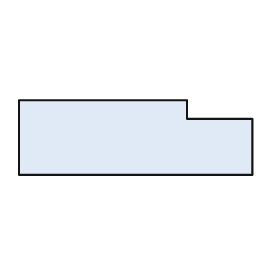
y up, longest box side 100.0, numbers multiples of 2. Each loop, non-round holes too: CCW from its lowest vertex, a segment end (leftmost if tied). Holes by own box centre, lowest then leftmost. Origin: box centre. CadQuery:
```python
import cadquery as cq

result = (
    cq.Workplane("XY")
    .moveTo(-50.0, -16.0)
    .lineTo(50.0, -16.0)
    .lineTo(50.0, 8.0)
    .lineTo(22.0, 8.0)
    .lineTo(22.0, 16.0)
    .lineTo(-50.0, 16.0)
    .close()
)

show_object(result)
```